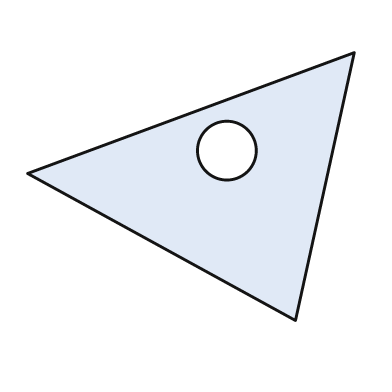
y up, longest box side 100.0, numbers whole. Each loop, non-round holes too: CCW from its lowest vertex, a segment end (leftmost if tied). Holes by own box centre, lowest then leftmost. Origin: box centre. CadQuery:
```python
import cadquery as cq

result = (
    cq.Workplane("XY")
    .moveTo(32.0, -41.0)
    .lineTo(50.0, 41.0)
    .lineTo(-50.0, 4.0)
    .close()
    .moveTo(11.0, 11.0)
    .circle(9.0)
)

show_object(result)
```